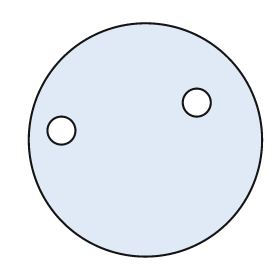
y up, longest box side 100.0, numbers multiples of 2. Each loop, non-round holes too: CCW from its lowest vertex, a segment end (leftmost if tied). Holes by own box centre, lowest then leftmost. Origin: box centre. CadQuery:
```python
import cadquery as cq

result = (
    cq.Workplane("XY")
    .moveTo(0.0, 0.0)
    .circle(50.0)
    .moveTo(-36.0, 4.0)
    .circle(6.0)
    .moveTo(22.0, 16.0)
    .circle(6.0)
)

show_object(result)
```